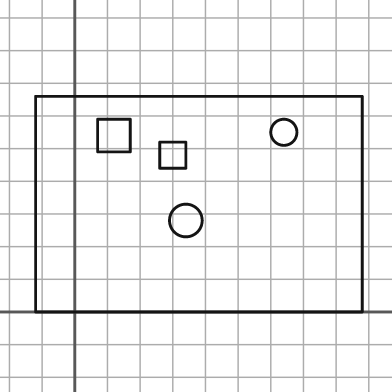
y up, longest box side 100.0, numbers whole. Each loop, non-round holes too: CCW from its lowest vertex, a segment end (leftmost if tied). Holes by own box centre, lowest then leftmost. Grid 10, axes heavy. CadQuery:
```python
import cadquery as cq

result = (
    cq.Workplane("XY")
    .moveTo(-12.0, 0.0)
    .lineTo(88.0, 0.0)
    .lineTo(88.0, 66.0)
    .lineTo(-12.0, 66.0)
    .close()
    .moveTo(34.0, 28.0)
    .circle(5.0)
    .moveTo(26.0, 44.0)
    .lineTo(34.0, 44.0)
    .lineTo(34.0, 52.0)
    .lineTo(26.0, 52.0)
    .close()
    .moveTo(7.0, 49.0)
    .lineTo(17.0, 49.0)
    .lineTo(17.0, 59.0)
    .lineTo(7.0, 59.0)
    .close()
    .moveTo(64.0, 55.0)
    .circle(4.0)
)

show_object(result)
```